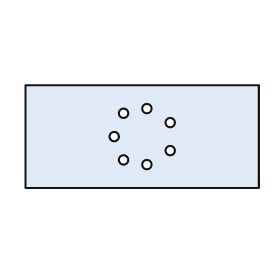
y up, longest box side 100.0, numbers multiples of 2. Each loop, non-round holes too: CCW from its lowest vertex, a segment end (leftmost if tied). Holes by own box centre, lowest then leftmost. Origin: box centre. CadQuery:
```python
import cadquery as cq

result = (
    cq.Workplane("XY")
    .moveTo(-50.0, -22.0)
    .lineTo(50.0, -22.0)
    .lineTo(50.0, 22.0)
    .lineTo(-50.0, 22.0)
    .close()
    .moveTo(2.0, -12.0)
    .circle(2.0)
    .moveTo(-8.0, -10.0)
    .circle(2.0)
    .moveTo(12.0, -6.0)
    .circle(2.0)
    .moveTo(-12.0, 0.0)
    .circle(2.0)
    .moveTo(12.0, 6.0)
    .circle(2.0)
    .moveTo(-8.0, 10.0)
    .circle(2.0)
    .moveTo(2.0, 12.0)
    .circle(2.0)
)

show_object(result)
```